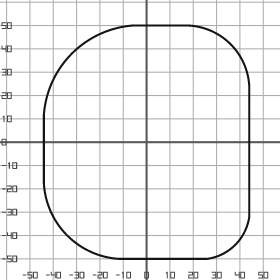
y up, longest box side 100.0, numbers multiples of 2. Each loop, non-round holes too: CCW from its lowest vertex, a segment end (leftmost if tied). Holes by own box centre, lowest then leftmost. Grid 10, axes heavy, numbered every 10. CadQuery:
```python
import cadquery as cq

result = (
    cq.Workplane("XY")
    .moveTo(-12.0, -50.0)
    .lineTo(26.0, -50.0)
    .threePointArc((38.0, -44.0), (44.0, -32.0))
    .lineTo(44.0, 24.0)
    .threePointArc((36.0, 42.0), (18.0, 50.0))
    .lineTo(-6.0, 50.0)
    .threePointArc((-32.0, 38.0), (-44.0, 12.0))
    .lineTo(-44.0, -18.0)
    .threePointArc((-34.0, -40.0), (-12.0, -50.0))
    .close()
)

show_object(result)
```